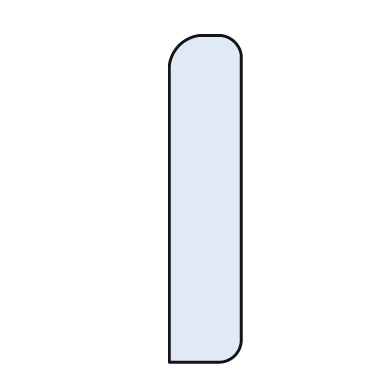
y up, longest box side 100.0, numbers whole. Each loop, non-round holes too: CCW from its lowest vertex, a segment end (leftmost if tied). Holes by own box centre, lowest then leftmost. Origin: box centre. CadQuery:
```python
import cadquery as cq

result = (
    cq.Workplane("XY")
    .moveTo(-11.0, -50.0)
    .lineTo(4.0, -50.0)
    .threePointArc((9.0, -48.0), (11.0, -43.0))
    .lineTo(11.0, 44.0)
    .threePointArc((9.0, 48.0), (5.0, 50.0))
    .lineTo(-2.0, 50.0)
    .threePointArc((-8.0, 47.0), (-11.0, 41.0))
    .close()
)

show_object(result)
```